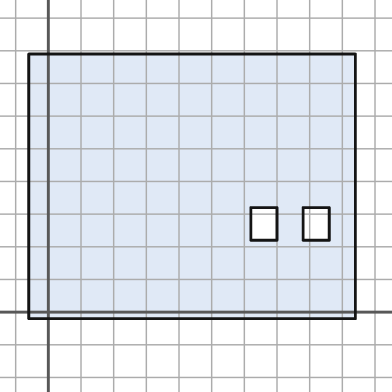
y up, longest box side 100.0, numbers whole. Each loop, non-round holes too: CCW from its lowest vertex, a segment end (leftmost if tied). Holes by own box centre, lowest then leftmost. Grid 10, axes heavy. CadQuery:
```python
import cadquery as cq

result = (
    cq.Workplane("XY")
    .moveTo(-6.0, -2.0)
    .lineTo(94.0, -2.0)
    .lineTo(94.0, 79.0)
    .lineTo(-6.0, 79.0)
    .close()
    .moveTo(62.0, 22.0)
    .lineTo(70.0, 22.0)
    .lineTo(70.0, 32.0)
    .lineTo(62.0, 32.0)
    .close()
    .moveTo(78.0, 22.0)
    .lineTo(86.0, 22.0)
    .lineTo(86.0, 32.0)
    .lineTo(78.0, 32.0)
    .close()
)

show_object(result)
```